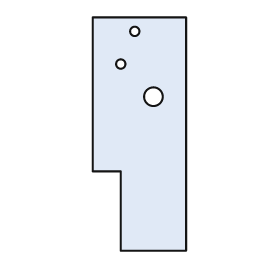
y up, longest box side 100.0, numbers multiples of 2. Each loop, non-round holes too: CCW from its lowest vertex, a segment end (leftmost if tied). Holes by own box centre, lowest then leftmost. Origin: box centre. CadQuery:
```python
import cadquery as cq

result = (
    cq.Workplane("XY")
    .moveTo(-8.0, -50.0)
    .lineTo(20.0, -50.0)
    .lineTo(20.0, 50.0)
    .lineTo(-20.0, 50.0)
    .lineTo(-20.0, -16.0)
    .lineTo(-8.0, -16.0)
    .close()
    .moveTo(6.0, 16.0)
    .circle(4.0)
    .moveTo(-8.0, 30.0)
    .circle(2.0)
    .moveTo(-2.0, 44.0)
    .circle(2.0)
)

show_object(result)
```